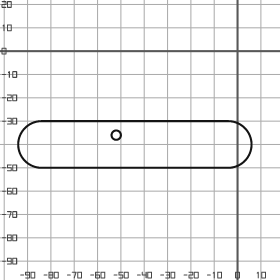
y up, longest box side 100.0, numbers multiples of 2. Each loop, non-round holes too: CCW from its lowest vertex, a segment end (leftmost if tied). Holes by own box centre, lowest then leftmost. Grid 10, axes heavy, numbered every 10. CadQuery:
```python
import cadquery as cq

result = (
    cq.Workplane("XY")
    .moveTo(-84.0, -50.0)
    .lineTo(-4.0, -50.0)
    .threePointArc((6.0, -40.0), (-4.0, -30.0))
    .lineTo(-84.0, -30.0)
    .threePointArc((-94.0, -40.0), (-84.0, -50.0))
    .close()
    .moveTo(-52.0, -36.0)
    .circle(2.0)
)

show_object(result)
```